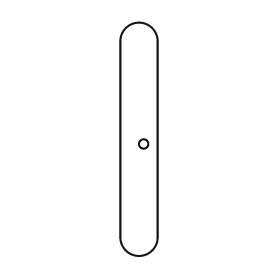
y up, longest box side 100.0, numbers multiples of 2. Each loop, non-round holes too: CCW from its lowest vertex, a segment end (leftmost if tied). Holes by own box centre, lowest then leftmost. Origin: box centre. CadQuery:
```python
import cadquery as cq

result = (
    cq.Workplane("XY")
    .moveTo(-8.0, -42.0)
    .threePointArc((0.0, -50.0), (8.0, -42.0))
    .lineTo(8.0, 42.0)
    .threePointArc((0.0, 50.0), (-8.0, 42.0))
    .close()
    .moveTo(2.0, -2.0)
    .circle(2.0)
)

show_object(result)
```